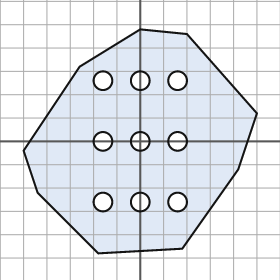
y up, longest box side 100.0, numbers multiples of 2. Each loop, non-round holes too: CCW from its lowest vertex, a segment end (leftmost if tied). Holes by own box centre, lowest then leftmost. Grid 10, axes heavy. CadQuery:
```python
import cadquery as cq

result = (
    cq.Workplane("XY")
    .moveTo(-18.0, -48.0)
    .lineTo(18.0, -46.0)
    .lineTo(42.0, -12.0)
    .lineTo(50.0, 12.0)
    .lineTo(20.0, 46.0)
    .lineTo(0.0, 48.0)
    .lineTo(-26.0, 32.0)
    .lineTo(-50.0, -4.0)
    .lineTo(-44.0, -22.0)
    .close()
    .moveTo(-16.0, -26.0)
    .circle(4.0)
    .moveTo(0.0, -26.0)
    .circle(4.0)
    .moveTo(16.0, -26.0)
    .circle(4.0)
    .moveTo(-16.0, 0.0)
    .circle(4.0)
    .moveTo(0.0, 0.0)
    .circle(4.0)
    .moveTo(16.0, 0.0)
    .circle(4.0)
    .moveTo(-16.0, 26.0)
    .circle(4.0)
    .moveTo(0.0, 26.0)
    .circle(4.0)
    .moveTo(16.0, 26.0)
    .circle(4.0)
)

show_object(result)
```